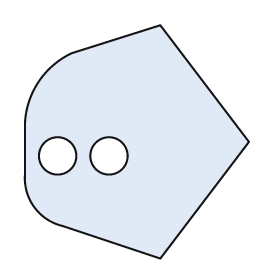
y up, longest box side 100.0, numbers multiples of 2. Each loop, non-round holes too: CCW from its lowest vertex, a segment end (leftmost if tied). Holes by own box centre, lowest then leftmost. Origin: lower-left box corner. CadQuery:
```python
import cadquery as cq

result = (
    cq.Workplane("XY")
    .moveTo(58.0, 0.0)
    .lineTo(96.0, 50.0)
    .lineTo(58.0, 100.0)
    .lineTo(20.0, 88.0)
    .threePointArc((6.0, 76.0), (0.0, 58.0))
    .lineTo(0.0, 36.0)
    .threePointArc((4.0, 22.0), (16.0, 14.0))
    .close()
    .moveTo(14.0, 44.0)
    .circle(8.0)
    .moveTo(36.0, 44.0)
    .circle(8.0)
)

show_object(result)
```